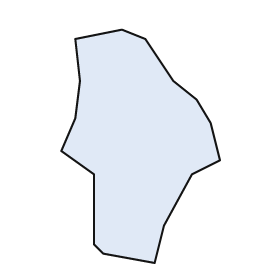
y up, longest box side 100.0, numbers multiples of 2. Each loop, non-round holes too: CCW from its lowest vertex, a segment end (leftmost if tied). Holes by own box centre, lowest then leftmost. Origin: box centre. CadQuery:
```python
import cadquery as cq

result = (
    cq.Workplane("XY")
    .moveTo(6.0, -50.0)
    .lineTo(10.0, -34.0)
    .lineTo(22.0, -12.0)
    .lineTo(34.0, -6.0)
    .lineTo(30.0, 10.0)
    .lineTo(24.0, 20.0)
    .lineTo(14.0, 28.0)
    .lineTo(2.0, 46.0)
    .lineTo(-8.0, 50.0)
    .lineTo(-28.0, 46.0)
    .lineTo(-26.0, 28.0)
    .lineTo(-28.0, 12.0)
    .lineTo(-34.0, -2.0)
    .lineTo(-20.0, -12.0)
    .lineTo(-20.0, -42.0)
    .lineTo(-16.0, -46.0)
    .close()
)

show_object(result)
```